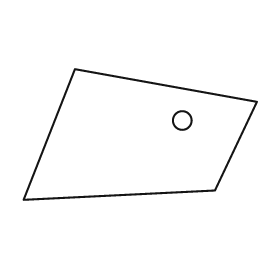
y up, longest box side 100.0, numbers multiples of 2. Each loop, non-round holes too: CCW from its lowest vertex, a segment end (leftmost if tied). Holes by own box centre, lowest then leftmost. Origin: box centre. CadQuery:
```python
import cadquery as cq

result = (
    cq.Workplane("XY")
    .moveTo(-50.0, -28.0)
    .lineTo(32.0, -24.0)
    .lineTo(50.0, 14.0)
    .lineTo(-28.0, 28.0)
    .close()
    .moveTo(18.0, 6.0)
    .circle(4.0)
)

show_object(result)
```